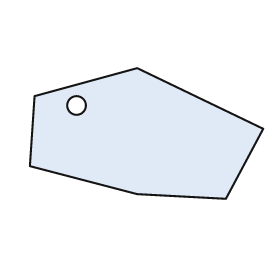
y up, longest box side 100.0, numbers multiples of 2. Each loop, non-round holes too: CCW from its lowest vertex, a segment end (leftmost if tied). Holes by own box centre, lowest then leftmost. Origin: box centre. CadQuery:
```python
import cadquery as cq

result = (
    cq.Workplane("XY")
    .moveTo(34.0, -28.0)
    .lineTo(50.0, 2.0)
    .lineTo(-4.0, 28.0)
    .lineTo(-48.0, 16.0)
    .lineTo(-50.0, -14.0)
    .lineTo(-4.0, -26.0)
    .close()
    .moveTo(-30.0, 12.0)
    .circle(4.0)
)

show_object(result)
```